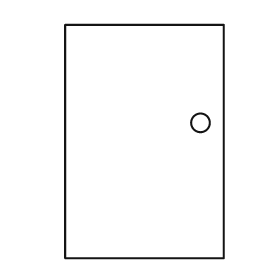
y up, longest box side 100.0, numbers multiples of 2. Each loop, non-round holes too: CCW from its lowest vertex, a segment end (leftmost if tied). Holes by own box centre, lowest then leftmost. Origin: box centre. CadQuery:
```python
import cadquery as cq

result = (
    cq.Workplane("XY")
    .moveTo(-34.0, -50.0)
    .lineTo(34.0, -50.0)
    .lineTo(34.0, 50.0)
    .lineTo(-34.0, 50.0)
    .close()
    .moveTo(24.0, 8.0)
    .circle(4.0)
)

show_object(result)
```